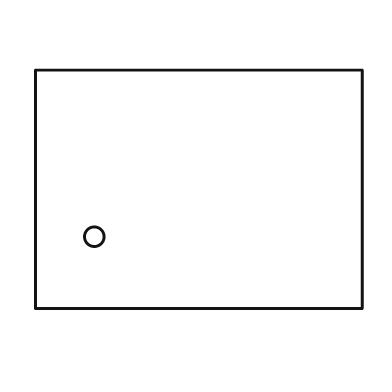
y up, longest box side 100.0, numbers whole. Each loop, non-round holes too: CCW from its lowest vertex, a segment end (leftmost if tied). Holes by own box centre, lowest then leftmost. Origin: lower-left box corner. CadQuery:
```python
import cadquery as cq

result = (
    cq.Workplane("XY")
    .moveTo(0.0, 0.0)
    .lineTo(100.0, 0.0)
    .lineTo(100.0, 73.0)
    .lineTo(0.0, 73.0)
    .close()
    .moveTo(18.0, 22.0)
    .circle(3.0)
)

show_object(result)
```